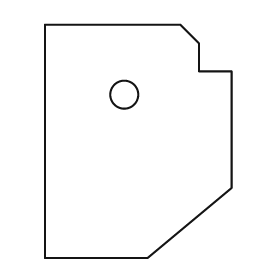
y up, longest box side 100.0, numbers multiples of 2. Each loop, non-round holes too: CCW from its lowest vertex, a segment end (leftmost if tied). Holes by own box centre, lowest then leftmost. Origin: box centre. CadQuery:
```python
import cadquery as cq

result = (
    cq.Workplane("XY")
    .moveTo(-40.0, -50.0)
    .lineTo(4.0, -50.0)
    .lineTo(40.0, -20.0)
    .lineTo(40.0, 30.0)
    .lineTo(26.0, 30.0)
    .lineTo(26.0, 42.0)
    .lineTo(18.0, 50.0)
    .lineTo(-40.0, 50.0)
    .close()
    .moveTo(-6.0, 20.0)
    .circle(6.0)
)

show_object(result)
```